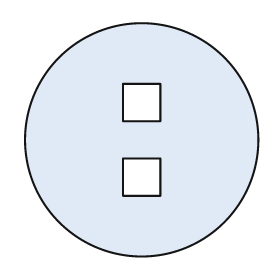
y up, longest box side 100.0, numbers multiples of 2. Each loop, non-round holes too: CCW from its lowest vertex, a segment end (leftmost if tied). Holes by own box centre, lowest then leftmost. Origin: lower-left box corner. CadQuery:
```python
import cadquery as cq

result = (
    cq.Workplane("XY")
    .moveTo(50.0, 50.0)
    .circle(50.0)
    .moveTo(42.0, 26.0)
    .lineTo(58.0, 26.0)
    .lineTo(58.0, 42.0)
    .lineTo(42.0, 42.0)
    .close()
    .moveTo(42.0, 58.0)
    .lineTo(58.0, 58.0)
    .lineTo(58.0, 74.0)
    .lineTo(42.0, 74.0)
    .close()
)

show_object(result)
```